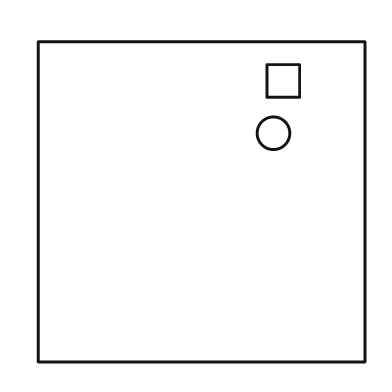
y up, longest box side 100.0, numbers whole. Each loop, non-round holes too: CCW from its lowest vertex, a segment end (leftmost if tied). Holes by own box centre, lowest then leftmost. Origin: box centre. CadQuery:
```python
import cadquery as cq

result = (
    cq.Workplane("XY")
    .moveTo(-50.0, -49.0)
    .lineTo(50.0, -49.0)
    .lineTo(50.0, 49.0)
    .lineTo(-50.0, 49.0)
    .close()
    .moveTo(22.0, 21.0)
    .circle(5.0)
    .moveTo(20.0, 32.0)
    .lineTo(30.0, 32.0)
    .lineTo(30.0, 42.0)
    .lineTo(20.0, 42.0)
    .close()
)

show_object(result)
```